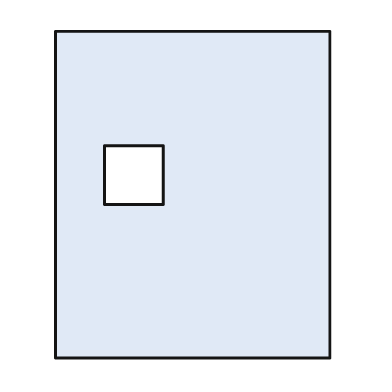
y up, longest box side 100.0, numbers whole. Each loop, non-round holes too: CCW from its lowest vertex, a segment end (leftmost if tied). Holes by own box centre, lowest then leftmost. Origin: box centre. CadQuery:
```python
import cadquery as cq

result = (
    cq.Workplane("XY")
    .moveTo(-42.0, -50.0)
    .lineTo(42.0, -50.0)
    .lineTo(42.0, 50.0)
    .lineTo(-42.0, 50.0)
    .close()
    .moveTo(-27.0, -3.0)
    .lineTo(-9.0, -3.0)
    .lineTo(-9.0, 15.0)
    .lineTo(-27.0, 15.0)
    .close()
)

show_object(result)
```